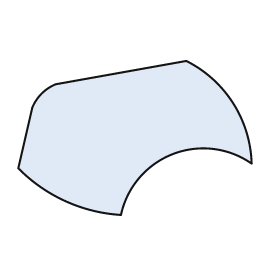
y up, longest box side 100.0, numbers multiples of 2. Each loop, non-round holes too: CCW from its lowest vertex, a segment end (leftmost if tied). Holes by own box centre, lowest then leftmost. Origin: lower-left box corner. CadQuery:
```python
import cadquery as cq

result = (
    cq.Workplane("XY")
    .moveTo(44.0, 0.0)
    .threePointArc((66.0, 26.0), (100.0, 22.0))
    .threePointArc((92.0, 48.0), (72.0, 66.0))
    .lineTo(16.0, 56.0)
    .threePointArc((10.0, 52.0), (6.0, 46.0))
    .lineTo(0.0, 20.0)
    .threePointArc((20.0, 6.0), (44.0, 0.0))
    .close()
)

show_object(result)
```